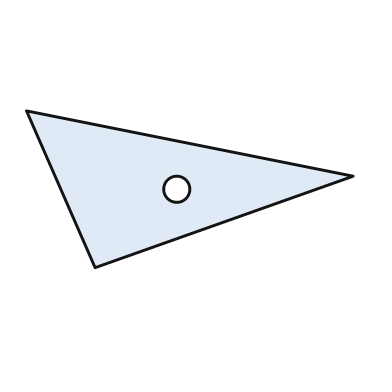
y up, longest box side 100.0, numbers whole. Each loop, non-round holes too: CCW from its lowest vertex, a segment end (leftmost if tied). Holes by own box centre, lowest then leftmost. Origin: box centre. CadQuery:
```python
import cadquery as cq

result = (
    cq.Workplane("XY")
    .moveTo(-29.0, -24.0)
    .lineTo(50.0, 4.0)
    .lineTo(-50.0, 24.0)
    .close()
    .moveTo(-4.0, 0.0)
    .circle(4.0)
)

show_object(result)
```